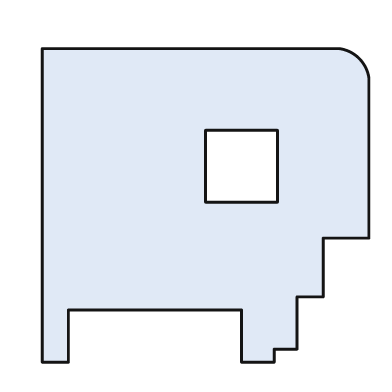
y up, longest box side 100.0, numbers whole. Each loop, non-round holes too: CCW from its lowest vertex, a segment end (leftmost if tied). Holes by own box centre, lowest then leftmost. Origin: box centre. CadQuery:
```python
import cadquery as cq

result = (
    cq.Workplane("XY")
    .moveTo(-50.0, -48.0)
    .lineTo(-42.0, -48.0)
    .lineTo(-42.0, -32.0)
    .lineTo(11.0, -32.0)
    .lineTo(11.0, -48.0)
    .lineTo(21.0, -48.0)
    .lineTo(21.0, -44.0)
    .lineTo(28.0, -44.0)
    .lineTo(28.0, -28.0)
    .lineTo(36.0, -28.0)
    .lineTo(36.0, -10.0)
    .lineTo(50.0, -10.0)
    .lineTo(50.0, 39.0)
    .threePointArc((47.0, 45.0), (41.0, 48.0))
    .lineTo(-50.0, 48.0)
    .close()
    .moveTo(0.0, 1.0)
    .lineTo(22.0, 1.0)
    .lineTo(22.0, 23.0)
    .lineTo(0.0, 23.0)
    .close()
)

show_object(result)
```